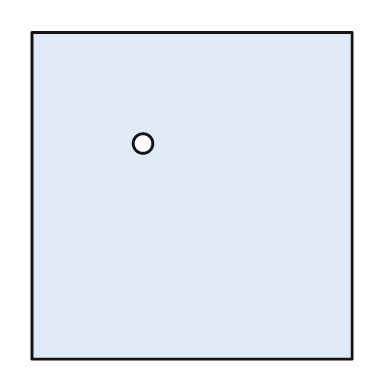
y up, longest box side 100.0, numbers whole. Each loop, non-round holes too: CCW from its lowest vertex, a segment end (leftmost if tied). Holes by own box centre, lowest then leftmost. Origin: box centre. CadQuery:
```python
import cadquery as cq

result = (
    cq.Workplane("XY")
    .moveTo(-49.0, -50.0)
    .lineTo(49.0, -50.0)
    .lineTo(49.0, 50.0)
    .lineTo(-49.0, 50.0)
    .close()
    .moveTo(-15.0, 16.0)
    .circle(3.0)
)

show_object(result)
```